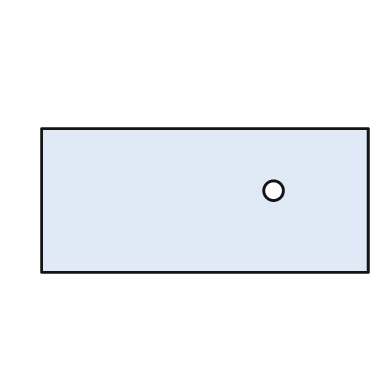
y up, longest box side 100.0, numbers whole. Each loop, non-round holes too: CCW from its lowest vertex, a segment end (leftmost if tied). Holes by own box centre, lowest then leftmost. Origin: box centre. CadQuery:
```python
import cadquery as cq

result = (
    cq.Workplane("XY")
    .moveTo(-50.0, -22.0)
    .lineTo(50.0, -22.0)
    .lineTo(50.0, 22.0)
    .lineTo(-50.0, 22.0)
    .close()
    .moveTo(21.0, 3.0)
    .circle(3.0)
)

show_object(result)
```